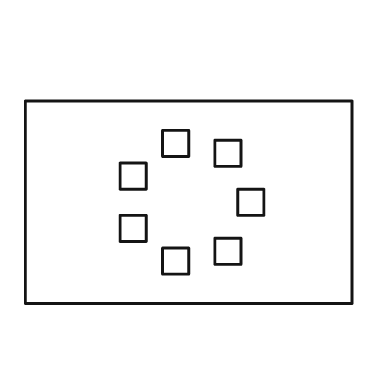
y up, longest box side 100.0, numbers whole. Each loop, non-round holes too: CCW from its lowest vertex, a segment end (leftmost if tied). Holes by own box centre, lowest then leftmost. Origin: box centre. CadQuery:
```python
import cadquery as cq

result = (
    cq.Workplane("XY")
    .moveTo(-50.0, -31.0)
    .lineTo(50.0, -31.0)
    .lineTo(50.0, 31.0)
    .lineTo(-50.0, 31.0)
    .close()
    .moveTo(-8.0, -22.0)
    .lineTo(0.0, -22.0)
    .lineTo(0.0, -14.0)
    .lineTo(-8.0, -14.0)
    .close()
    .moveTo(8.0, -19.0)
    .lineTo(16.0, -19.0)
    .lineTo(16.0, -11.0)
    .lineTo(8.0, -11.0)
    .close()
    .moveTo(-21.0, -12.0)
    .lineTo(-13.0, -12.0)
    .lineTo(-13.0, -4.0)
    .lineTo(-21.0, -4.0)
    .close()
    .moveTo(15.0, -4.0)
    .lineTo(23.0, -4.0)
    .lineTo(23.0, 4.0)
    .lineTo(15.0, 4.0)
    .close()
    .moveTo(-21.0, 4.0)
    .lineTo(-13.0, 4.0)
    .lineTo(-13.0, 12.0)
    .lineTo(-21.0, 12.0)
    .close()
    .moveTo(8.0, 11.0)
    .lineTo(16.0, 11.0)
    .lineTo(16.0, 19.0)
    .lineTo(8.0, 19.0)
    .close()
    .moveTo(-8.0, 14.0)
    .lineTo(0.0, 14.0)
    .lineTo(0.0, 22.0)
    .lineTo(-8.0, 22.0)
    .close()
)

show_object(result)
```